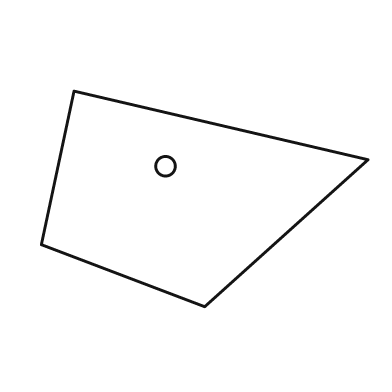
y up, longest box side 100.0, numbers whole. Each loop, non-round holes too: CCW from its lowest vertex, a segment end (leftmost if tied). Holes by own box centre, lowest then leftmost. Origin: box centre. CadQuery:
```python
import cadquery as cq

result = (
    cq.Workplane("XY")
    .moveTo(0.0, -33.0)
    .lineTo(50.0, 12.0)
    .lineTo(-40.0, 33.0)
    .lineTo(-50.0, -14.0)
    .close()
    .moveTo(-12.0, 10.0)
    .circle(3.0)
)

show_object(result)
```